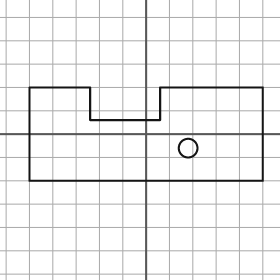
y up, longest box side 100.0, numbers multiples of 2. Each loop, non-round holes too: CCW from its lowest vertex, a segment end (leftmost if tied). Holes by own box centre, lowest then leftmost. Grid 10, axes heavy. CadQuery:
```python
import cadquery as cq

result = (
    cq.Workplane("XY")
    .moveTo(-50.0, -20.0)
    .lineTo(50.0, -20.0)
    .lineTo(50.0, 20.0)
    .lineTo(6.0, 20.0)
    .lineTo(6.0, 6.0)
    .lineTo(-24.0, 6.0)
    .lineTo(-24.0, 20.0)
    .lineTo(-50.0, 20.0)
    .close()
    .moveTo(18.0, -6.0)
    .circle(4.0)
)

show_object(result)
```